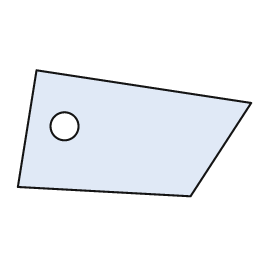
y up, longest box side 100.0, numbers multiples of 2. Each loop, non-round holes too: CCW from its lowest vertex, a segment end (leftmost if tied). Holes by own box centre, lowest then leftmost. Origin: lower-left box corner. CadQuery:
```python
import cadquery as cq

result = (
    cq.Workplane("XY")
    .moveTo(74.0, 0.0)
    .lineTo(100.0, 40.0)
    .lineTo(8.0, 54.0)
    .lineTo(0.0, 4.0)
    .close()
    .moveTo(20.0, 30.0)
    .circle(6.0)
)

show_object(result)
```